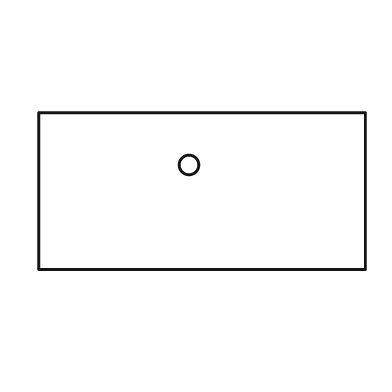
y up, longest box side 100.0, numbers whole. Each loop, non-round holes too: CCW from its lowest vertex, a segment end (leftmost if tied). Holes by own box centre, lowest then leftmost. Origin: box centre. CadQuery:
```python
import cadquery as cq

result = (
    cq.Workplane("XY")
    .moveTo(-50.0, -24.0)
    .lineTo(50.0, -24.0)
    .lineTo(50.0, 24.0)
    .lineTo(-50.0, 24.0)
    .close()
    .moveTo(-4.0, 8.0)
    .circle(3.0)
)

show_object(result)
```